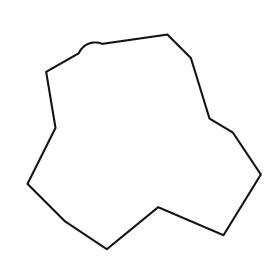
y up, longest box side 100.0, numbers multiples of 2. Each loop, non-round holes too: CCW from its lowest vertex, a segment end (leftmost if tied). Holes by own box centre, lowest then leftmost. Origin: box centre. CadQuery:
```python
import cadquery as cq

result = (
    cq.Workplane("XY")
    .moveTo(-16.0, -46.0)
    .lineTo(6.0, -28.0)
    .lineTo(34.0, -40.0)
    .lineTo(50.0, -14.0)
    .lineTo(38.0, 4.0)
    .lineTo(28.0, 10.0)
    .lineTo(20.0, 36.0)
    .lineTo(10.0, 46.0)
    .lineTo(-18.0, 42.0)
    .threePointArc((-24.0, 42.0), (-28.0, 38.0))
    .lineTo(-42.0, 30.0)
    .lineTo(-38.0, 6.0)
    .lineTo(-50.0, -18.0)
    .lineTo(-34.0, -34.0)
    .close()
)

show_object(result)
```